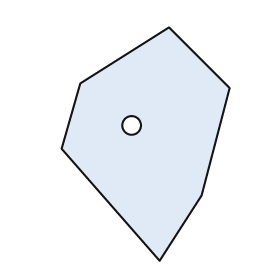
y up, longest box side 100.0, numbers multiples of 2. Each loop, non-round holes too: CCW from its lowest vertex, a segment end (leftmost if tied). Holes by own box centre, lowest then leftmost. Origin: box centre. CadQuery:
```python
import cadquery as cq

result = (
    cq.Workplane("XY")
    .moveTo(6.0, -50.0)
    .lineTo(24.0, -22.0)
    .lineTo(36.0, 24.0)
    .lineTo(10.0, 50.0)
    .lineTo(-28.0, 26.0)
    .lineTo(-36.0, -2.0)
    .close()
    .moveTo(-6.0, 8.0)
    .circle(4.0)
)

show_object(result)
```